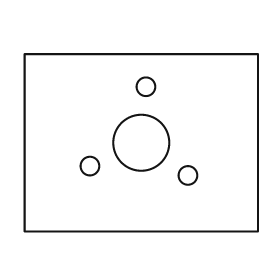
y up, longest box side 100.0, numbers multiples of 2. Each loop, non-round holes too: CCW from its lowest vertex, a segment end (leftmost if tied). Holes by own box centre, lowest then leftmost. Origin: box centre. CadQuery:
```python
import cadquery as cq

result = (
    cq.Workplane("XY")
    .moveTo(-50.0, -38.0)
    .lineTo(50.0, -38.0)
    .lineTo(50.0, 38.0)
    .lineTo(-50.0, 38.0)
    .close()
    .moveTo(20.0, -14.0)
    .circle(4.0)
    .moveTo(-22.0, -10.0)
    .circle(4.0)
    .moveTo(0.0, 0.0)
    .circle(12.0)
    .moveTo(2.0, 24.0)
    .circle(4.0)
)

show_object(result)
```